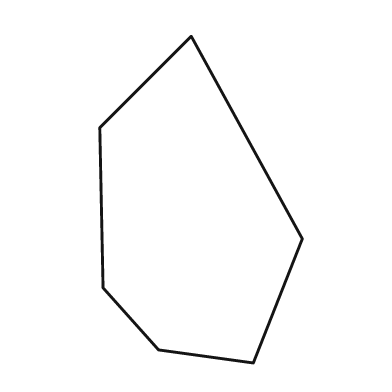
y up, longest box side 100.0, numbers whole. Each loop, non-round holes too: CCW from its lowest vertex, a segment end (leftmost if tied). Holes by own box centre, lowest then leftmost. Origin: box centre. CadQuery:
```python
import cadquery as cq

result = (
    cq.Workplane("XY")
    .moveTo(16.0, -50.0)
    .lineTo(31.0, -12.0)
    .lineTo(-3.0, 50.0)
    .lineTo(-31.0, 22.0)
    .lineTo(-30.0, -27.0)
    .lineTo(-13.0, -46.0)
    .close()
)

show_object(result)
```